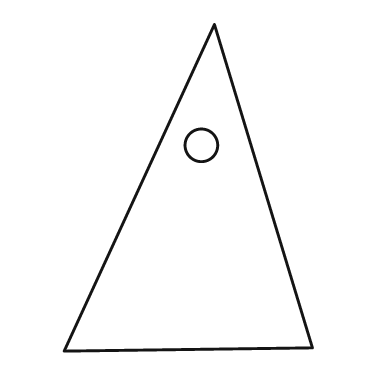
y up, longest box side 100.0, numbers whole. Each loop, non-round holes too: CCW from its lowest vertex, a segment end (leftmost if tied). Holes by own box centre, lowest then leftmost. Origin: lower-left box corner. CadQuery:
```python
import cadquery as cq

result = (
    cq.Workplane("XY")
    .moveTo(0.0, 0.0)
    .lineTo(76.0, 1.0)
    .lineTo(46.0, 100.0)
    .close()
    .moveTo(42.0, 63.0)
    .circle(5.0)
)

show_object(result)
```